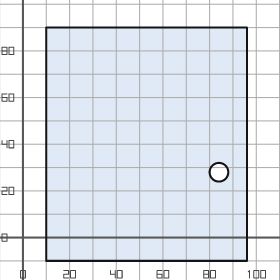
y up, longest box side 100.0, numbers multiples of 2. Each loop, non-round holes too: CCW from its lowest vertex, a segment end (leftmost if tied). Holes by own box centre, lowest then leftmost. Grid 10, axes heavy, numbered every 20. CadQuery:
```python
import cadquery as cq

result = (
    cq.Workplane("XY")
    .moveTo(10.0, -10.0)
    .lineTo(96.0, -10.0)
    .lineTo(96.0, 90.0)
    .lineTo(10.0, 90.0)
    .close()
    .moveTo(84.0, 28.0)
    .circle(4.0)
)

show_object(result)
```